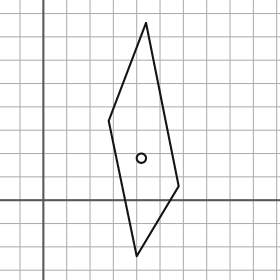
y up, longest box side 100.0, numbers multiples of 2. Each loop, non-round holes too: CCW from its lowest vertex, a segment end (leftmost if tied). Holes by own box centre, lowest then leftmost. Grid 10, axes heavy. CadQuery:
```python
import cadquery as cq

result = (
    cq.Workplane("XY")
    .moveTo(40.0, -24.0)
    .lineTo(58.0, 6.0)
    .lineTo(44.0, 76.0)
    .lineTo(28.0, 34.0)
    .close()
    .moveTo(42.0, 18.0)
    .circle(2.0)
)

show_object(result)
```